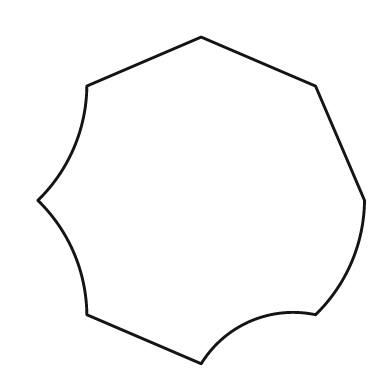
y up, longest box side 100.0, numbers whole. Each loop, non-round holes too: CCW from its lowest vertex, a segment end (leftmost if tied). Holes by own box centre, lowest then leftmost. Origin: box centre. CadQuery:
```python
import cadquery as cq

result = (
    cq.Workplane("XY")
    .moveTo(0.0, -50.0)
    .threePointArc((15.0, -37.0), (35.0, -35.0))
    .threePointArc((46.0, -19.0), (50.0, 0.0))
    .lineTo(35.0, 35.0)
    .lineTo(0.0, 50.0)
    .lineTo(-35.0, 35.0)
    .threePointArc((-39.0, 16.0), (-50.0, 0.0))
    .threePointArc((-39.0, -16.0), (-35.0, -35.0))
    .close()
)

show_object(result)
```